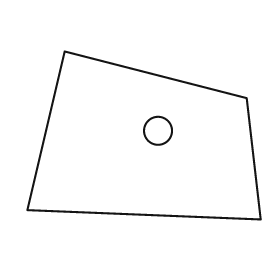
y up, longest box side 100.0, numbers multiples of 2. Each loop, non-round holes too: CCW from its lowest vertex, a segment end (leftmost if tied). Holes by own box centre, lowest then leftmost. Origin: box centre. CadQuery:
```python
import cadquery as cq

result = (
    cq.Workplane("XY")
    .moveTo(50.0, -36.0)
    .lineTo(44.0, 16.0)
    .lineTo(-34.0, 36.0)
    .lineTo(-50.0, -32.0)
    .close()
    .moveTo(6.0, 2.0)
    .circle(6.0)
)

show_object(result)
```